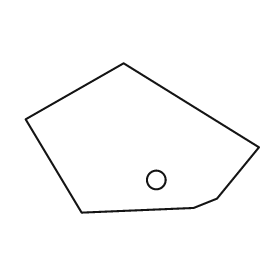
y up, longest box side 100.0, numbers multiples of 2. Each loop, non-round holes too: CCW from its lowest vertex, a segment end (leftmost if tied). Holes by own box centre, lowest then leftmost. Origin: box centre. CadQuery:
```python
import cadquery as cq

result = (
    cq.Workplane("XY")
    .moveTo(-26.0, -32.0)
    .lineTo(22.0, -30.0)
    .lineTo(32.0, -26.0)
    .lineTo(50.0, -4.0)
    .lineTo(-8.0, 32.0)
    .lineTo(-50.0, 8.0)
    .close()
    .moveTo(6.0, -18.0)
    .circle(4.0)
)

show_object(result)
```